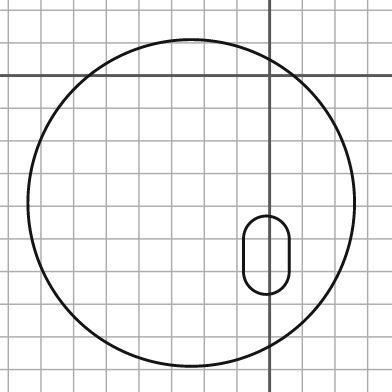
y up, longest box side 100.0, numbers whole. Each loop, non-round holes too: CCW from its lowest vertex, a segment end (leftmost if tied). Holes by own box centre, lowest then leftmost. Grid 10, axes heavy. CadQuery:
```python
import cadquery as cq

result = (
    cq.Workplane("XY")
    .moveTo(-24.0, -39.0)
    .circle(50.0)
    .moveTo(-8.0, -60.0)
    .threePointArc((-1.0, -67.0), (6.0, -60.0))
    .lineTo(6.0, -50.0)
    .threePointArc((-1.0, -43.0), (-8.0, -50.0))
    .close()
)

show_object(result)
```